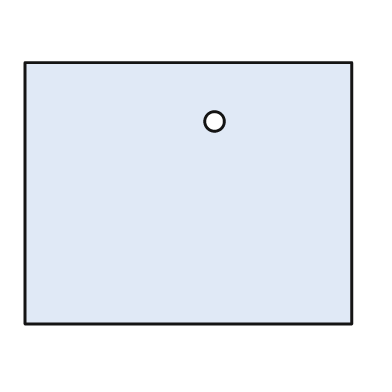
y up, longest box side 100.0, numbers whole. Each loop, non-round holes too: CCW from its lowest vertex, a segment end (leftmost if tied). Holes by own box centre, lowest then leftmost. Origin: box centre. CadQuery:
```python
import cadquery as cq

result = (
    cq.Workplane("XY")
    .moveTo(-50.0, -40.0)
    .lineTo(50.0, -40.0)
    .lineTo(50.0, 40.0)
    .lineTo(-50.0, 40.0)
    .close()
    .moveTo(8.0, 22.0)
    .circle(3.0)
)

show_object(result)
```